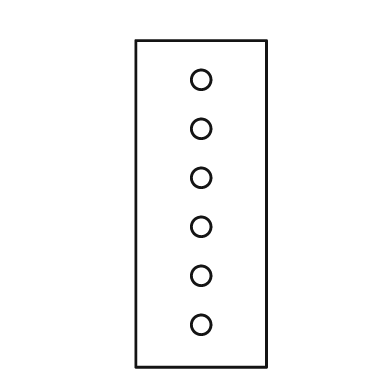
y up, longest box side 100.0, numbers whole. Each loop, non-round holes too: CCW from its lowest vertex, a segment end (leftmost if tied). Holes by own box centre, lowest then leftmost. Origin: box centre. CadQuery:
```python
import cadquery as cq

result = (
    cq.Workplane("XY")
    .moveTo(-20.0, -50.0)
    .lineTo(20.0, -50.0)
    .lineTo(20.0, 50.0)
    .lineTo(-20.0, 50.0)
    .close()
    .moveTo(0.0, -37.0)
    .circle(3.0)
    .moveTo(0.0, -22.0)
    .circle(3.0)
    .moveTo(0.0, -7.0)
    .circle(3.0)
    .moveTo(0.0, 8.0)
    .circle(3.0)
    .moveTo(0.0, 23.0)
    .circle(3.0)
    .moveTo(0.0, 38.0)
    .circle(3.0)
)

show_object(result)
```